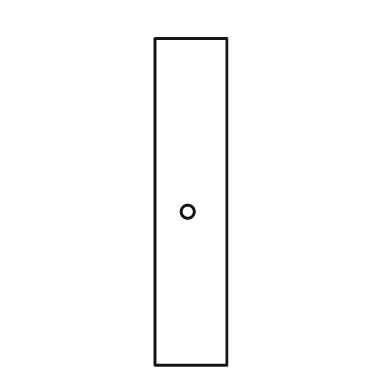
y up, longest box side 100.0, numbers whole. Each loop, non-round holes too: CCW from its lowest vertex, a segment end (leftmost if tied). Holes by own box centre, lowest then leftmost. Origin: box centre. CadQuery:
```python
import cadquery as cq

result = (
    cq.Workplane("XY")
    .moveTo(-11.0, -50.0)
    .lineTo(11.0, -50.0)
    .lineTo(11.0, 50.0)
    .lineTo(-11.0, 50.0)
    .close()
    .moveTo(-1.0, -3.0)
    .circle(2.0)
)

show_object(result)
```